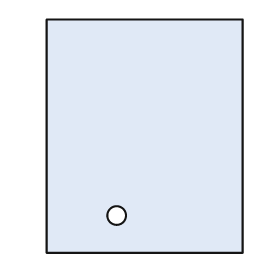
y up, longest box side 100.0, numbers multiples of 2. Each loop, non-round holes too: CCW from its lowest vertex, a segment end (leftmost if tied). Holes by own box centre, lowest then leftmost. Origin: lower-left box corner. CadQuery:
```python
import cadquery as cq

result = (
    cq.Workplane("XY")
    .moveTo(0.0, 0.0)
    .lineTo(84.0, 0.0)
    .lineTo(84.0, 100.0)
    .lineTo(0.0, 100.0)
    .close()
    .moveTo(30.0, 16.0)
    .circle(4.0)
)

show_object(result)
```